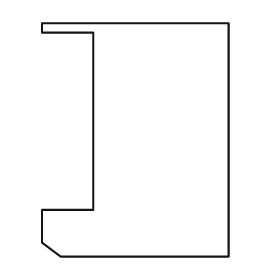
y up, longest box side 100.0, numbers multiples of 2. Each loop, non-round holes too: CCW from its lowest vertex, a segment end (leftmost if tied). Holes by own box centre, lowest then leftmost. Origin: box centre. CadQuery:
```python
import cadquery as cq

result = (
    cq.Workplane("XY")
    .moveTo(-32.0, -50.0)
    .lineTo(40.0, -50.0)
    .lineTo(40.0, 50.0)
    .lineTo(-40.0, 50.0)
    .lineTo(-40.0, 46.0)
    .lineTo(-18.0, 46.0)
    .lineTo(-18.0, -30.0)
    .lineTo(-40.0, -30.0)
    .lineTo(-40.0, -44.0)
    .close()
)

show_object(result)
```